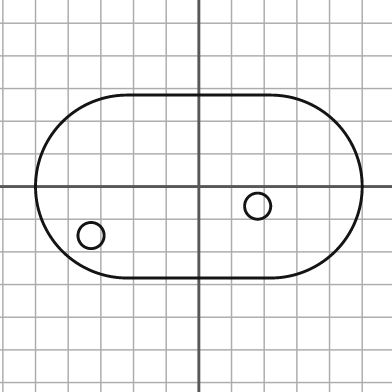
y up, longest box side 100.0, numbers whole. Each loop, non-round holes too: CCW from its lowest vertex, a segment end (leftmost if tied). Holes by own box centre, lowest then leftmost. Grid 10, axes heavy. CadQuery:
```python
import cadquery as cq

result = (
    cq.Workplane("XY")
    .moveTo(-22.0, -28.0)
    .lineTo(22.0, -28.0)
    .threePointArc((50.0, 0.0), (22.0, 28.0))
    .lineTo(-22.0, 28.0)
    .threePointArc((-50.0, 0.0), (-22.0, -28.0))
    .close()
    .moveTo(-33.0, -15.0)
    .circle(4.0)
    .moveTo(18.0, -6.0)
    .circle(4.0)
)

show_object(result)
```